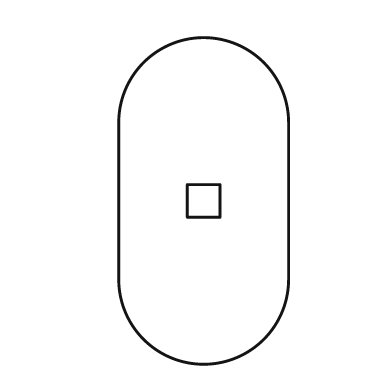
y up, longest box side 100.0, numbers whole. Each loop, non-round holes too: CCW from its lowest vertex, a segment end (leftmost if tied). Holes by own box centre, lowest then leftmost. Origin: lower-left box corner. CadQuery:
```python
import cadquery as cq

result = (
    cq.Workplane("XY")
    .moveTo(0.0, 26.0)
    .threePointArc((26.0, 0.0), (52.0, 26.0))
    .lineTo(52.0, 74.0)
    .threePointArc((26.0, 100.0), (0.0, 74.0))
    .close()
    .moveTo(21.0, 45.0)
    .lineTo(31.0, 45.0)
    .lineTo(31.0, 55.0)
    .lineTo(21.0, 55.0)
    .close()
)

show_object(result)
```